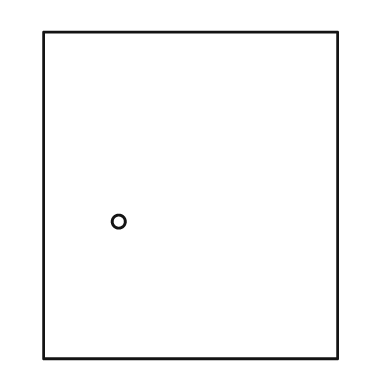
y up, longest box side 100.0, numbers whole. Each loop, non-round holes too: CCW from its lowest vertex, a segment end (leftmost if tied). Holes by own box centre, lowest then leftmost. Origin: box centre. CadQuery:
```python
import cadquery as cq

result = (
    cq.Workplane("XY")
    .moveTo(-45.0, -50.0)
    .lineTo(45.0, -50.0)
    .lineTo(45.0, 50.0)
    .lineTo(-45.0, 50.0)
    .close()
    .moveTo(-22.0, -8.0)
    .circle(2.0)
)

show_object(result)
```